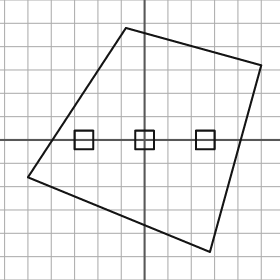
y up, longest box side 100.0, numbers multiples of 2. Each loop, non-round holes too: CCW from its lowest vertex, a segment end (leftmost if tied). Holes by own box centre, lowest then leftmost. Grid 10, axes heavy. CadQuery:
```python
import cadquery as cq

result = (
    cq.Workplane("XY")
    .moveTo(28.0, -48.0)
    .lineTo(50.0, 32.0)
    .lineTo(-8.0, 48.0)
    .lineTo(-50.0, -16.0)
    .close()
    .moveTo(-30.0, -4.0)
    .lineTo(-22.0, -4.0)
    .lineTo(-22.0, 4.0)
    .lineTo(-30.0, 4.0)
    .close()
    .moveTo(-4.0, -4.0)
    .lineTo(4.0, -4.0)
    .lineTo(4.0, 4.0)
    .lineTo(-4.0, 4.0)
    .close()
    .moveTo(22.0, -4.0)
    .lineTo(30.0, -4.0)
    .lineTo(30.0, 4.0)
    .lineTo(22.0, 4.0)
    .close()
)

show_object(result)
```